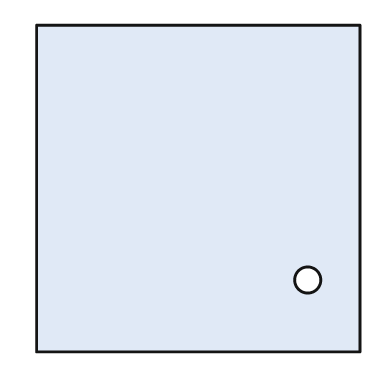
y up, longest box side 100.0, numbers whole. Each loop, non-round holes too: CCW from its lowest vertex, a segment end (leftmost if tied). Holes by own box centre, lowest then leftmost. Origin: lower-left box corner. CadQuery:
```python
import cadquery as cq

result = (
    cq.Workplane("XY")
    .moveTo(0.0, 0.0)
    .lineTo(99.0, 0.0)
    .lineTo(99.0, 100.0)
    .lineTo(0.0, 100.0)
    .close()
    .moveTo(83.0, 22.0)
    .circle(4.0)
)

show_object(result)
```